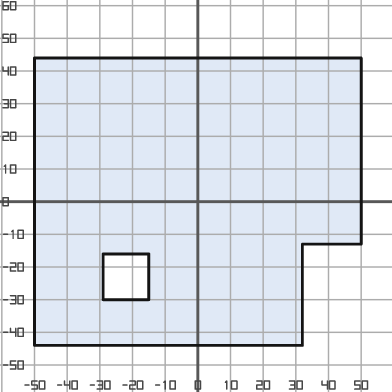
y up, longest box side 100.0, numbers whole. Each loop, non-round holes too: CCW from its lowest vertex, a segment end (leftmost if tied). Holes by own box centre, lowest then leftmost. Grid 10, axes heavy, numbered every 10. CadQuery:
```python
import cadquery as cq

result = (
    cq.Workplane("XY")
    .moveTo(-50.0, -44.0)
    .lineTo(32.0, -44.0)
    .lineTo(32.0, -13.0)
    .lineTo(50.0, -13.0)
    .lineTo(50.0, 44.0)
    .lineTo(-50.0, 44.0)
    .close()
    .moveTo(-29.0, -30.0)
    .lineTo(-15.0, -30.0)
    .lineTo(-15.0, -16.0)
    .lineTo(-29.0, -16.0)
    .close()
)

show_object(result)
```